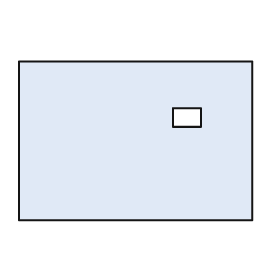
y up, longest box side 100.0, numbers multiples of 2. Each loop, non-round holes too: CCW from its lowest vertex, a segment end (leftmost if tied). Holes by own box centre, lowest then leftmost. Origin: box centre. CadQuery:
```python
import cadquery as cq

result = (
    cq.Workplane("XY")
    .moveTo(-50.0, -34.0)
    .lineTo(50.0, -34.0)
    .lineTo(50.0, 34.0)
    .lineTo(-50.0, 34.0)
    .close()
    .moveTo(16.0, 6.0)
    .lineTo(28.0, 6.0)
    .lineTo(28.0, 14.0)
    .lineTo(16.0, 14.0)
    .close()
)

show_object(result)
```